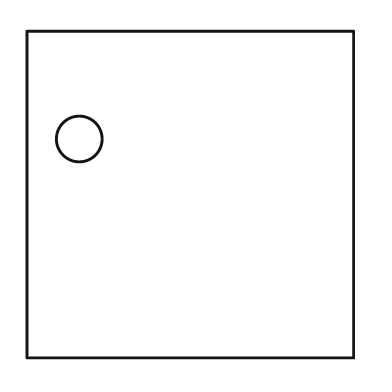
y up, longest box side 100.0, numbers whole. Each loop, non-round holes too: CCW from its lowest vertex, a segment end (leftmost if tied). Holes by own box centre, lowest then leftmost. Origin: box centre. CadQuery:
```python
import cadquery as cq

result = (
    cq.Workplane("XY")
    .moveTo(-50.0, -50.0)
    .lineTo(50.0, -50.0)
    .lineTo(50.0, 50.0)
    .lineTo(-50.0, 50.0)
    .close()
    .moveTo(-34.0, 17.0)
    .circle(7.0)
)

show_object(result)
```